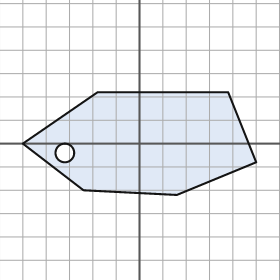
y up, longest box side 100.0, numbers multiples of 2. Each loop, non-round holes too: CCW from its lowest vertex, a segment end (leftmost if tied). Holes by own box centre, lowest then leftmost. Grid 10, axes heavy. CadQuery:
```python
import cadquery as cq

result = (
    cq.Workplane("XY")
    .moveTo(16.0, -22.0)
    .lineTo(50.0, -8.0)
    .lineTo(38.0, 22.0)
    .lineTo(-18.0, 22.0)
    .lineTo(-50.0, 0.0)
    .lineTo(-24.0, -20.0)
    .close()
    .moveTo(-32.0, -4.0)
    .circle(4.0)
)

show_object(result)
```